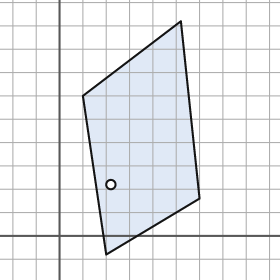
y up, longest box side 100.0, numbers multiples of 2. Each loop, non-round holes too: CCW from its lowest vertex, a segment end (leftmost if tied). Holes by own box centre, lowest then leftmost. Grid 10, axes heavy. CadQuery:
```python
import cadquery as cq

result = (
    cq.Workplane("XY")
    .moveTo(20.0, -8.0)
    .lineTo(60.0, 16.0)
    .lineTo(52.0, 92.0)
    .lineTo(10.0, 60.0)
    .close()
    .moveTo(22.0, 22.0)
    .circle(2.0)
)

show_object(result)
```